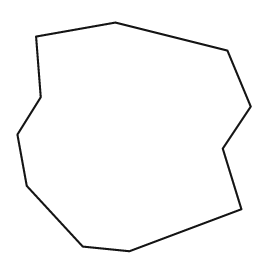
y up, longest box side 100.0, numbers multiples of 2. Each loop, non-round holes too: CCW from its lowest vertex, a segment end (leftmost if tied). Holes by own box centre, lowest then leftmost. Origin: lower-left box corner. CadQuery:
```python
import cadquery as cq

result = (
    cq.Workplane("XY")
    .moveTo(48.0, 0.0)
    .lineTo(96.0, 18.0)
    .lineTo(88.0, 44.0)
    .lineTo(100.0, 62.0)
    .lineTo(90.0, 86.0)
    .lineTo(42.0, 98.0)
    .lineTo(8.0, 92.0)
    .lineTo(10.0, 66.0)
    .lineTo(0.0, 50.0)
    .lineTo(4.0, 28.0)
    .lineTo(28.0, 2.0)
    .close()
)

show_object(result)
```